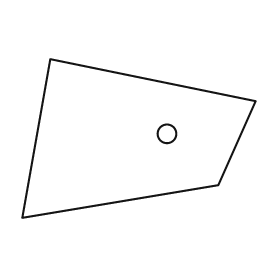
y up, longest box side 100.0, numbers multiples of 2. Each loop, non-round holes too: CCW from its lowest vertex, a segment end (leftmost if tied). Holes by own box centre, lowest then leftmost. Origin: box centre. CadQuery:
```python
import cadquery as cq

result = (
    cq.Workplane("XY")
    .moveTo(-50.0, -34.0)
    .lineTo(34.0, -20.0)
    .lineTo(50.0, 16.0)
    .lineTo(-38.0, 34.0)
    .close()
    .moveTo(12.0, 2.0)
    .circle(4.0)
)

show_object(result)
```